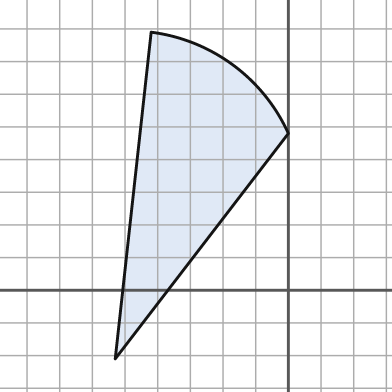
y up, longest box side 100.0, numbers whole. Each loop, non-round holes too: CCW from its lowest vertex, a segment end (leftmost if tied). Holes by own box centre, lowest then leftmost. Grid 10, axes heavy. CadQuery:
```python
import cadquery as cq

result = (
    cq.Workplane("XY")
    .moveTo(-53.0, -21.0)
    .lineTo(0.0, 48.0)
    .threePointArc((-17.0, 69.0), (-42.0, 79.0))
    .close()
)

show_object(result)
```